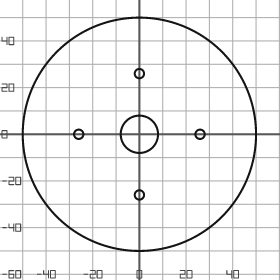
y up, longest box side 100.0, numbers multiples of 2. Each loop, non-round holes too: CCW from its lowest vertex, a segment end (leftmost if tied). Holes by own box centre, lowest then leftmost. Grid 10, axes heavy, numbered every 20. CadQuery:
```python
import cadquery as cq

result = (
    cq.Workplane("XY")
    .moveTo(0.0, 0.0)
    .circle(50.0)
    .moveTo(0.0, -26.0)
    .circle(2.0)
    .moveTo(-26.0, 0.0)
    .circle(2.0)
    .moveTo(0.0, 0.0)
    .circle(8.0)
    .moveTo(26.0, 0.0)
    .circle(2.0)
    .moveTo(0.0, 26.0)
    .circle(2.0)
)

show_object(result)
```